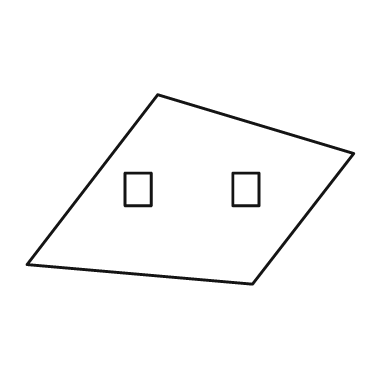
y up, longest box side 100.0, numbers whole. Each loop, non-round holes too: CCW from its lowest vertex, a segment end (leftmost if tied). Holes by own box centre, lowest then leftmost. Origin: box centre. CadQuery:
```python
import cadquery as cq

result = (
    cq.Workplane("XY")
    .moveTo(19.0, -29.0)
    .lineTo(50.0, 11.0)
    .lineTo(-10.0, 29.0)
    .lineTo(-50.0, -23.0)
    .close()
    .moveTo(-20.0, -5.0)
    .lineTo(-12.0, -5.0)
    .lineTo(-12.0, 5.0)
    .lineTo(-20.0, 5.0)
    .close()
    .moveTo(13.0, -5.0)
    .lineTo(21.0, -5.0)
    .lineTo(21.0, 5.0)
    .lineTo(13.0, 5.0)
    .close()
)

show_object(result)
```